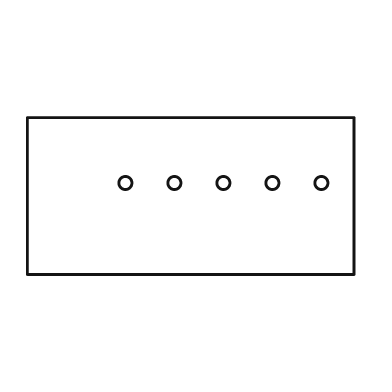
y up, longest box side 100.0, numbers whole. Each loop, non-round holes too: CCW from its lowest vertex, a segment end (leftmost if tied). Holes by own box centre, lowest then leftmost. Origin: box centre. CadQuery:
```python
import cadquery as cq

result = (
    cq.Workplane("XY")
    .moveTo(-50.0, -24.0)
    .lineTo(50.0, -24.0)
    .lineTo(50.0, 24.0)
    .lineTo(-50.0, 24.0)
    .close()
    .moveTo(-20.0, 4.0)
    .circle(2.0)
    .moveTo(-5.0, 4.0)
    .circle(2.0)
    .moveTo(10.0, 4.0)
    .circle(2.0)
    .moveTo(25.0, 4.0)
    .circle(2.0)
    .moveTo(40.0, 4.0)
    .circle(2.0)
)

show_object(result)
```